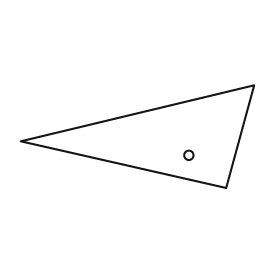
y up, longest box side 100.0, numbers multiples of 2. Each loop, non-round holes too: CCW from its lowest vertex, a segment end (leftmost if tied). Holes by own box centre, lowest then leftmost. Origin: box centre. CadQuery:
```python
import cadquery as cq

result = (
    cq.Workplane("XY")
    .moveTo(38.0, -22.0)
    .lineTo(50.0, 22.0)
    .lineTo(-50.0, -2.0)
    .close()
    .moveTo(22.0, -8.0)
    .circle(2.0)
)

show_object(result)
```